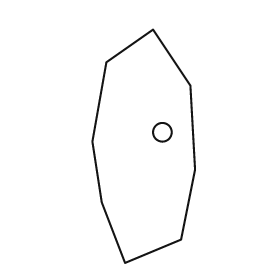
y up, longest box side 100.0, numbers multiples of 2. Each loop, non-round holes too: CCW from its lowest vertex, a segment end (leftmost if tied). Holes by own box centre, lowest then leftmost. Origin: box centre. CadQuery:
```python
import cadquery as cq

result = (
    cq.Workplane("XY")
    .moveTo(-8.0, -50.0)
    .lineTo(16.0, -40.0)
    .lineTo(22.0, -10.0)
    .lineTo(20.0, 26.0)
    .lineTo(4.0, 50.0)
    .lineTo(-16.0, 36.0)
    .lineTo(-22.0, 2.0)
    .lineTo(-18.0, -24.0)
    .close()
    .moveTo(8.0, 6.0)
    .circle(4.0)
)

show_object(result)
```